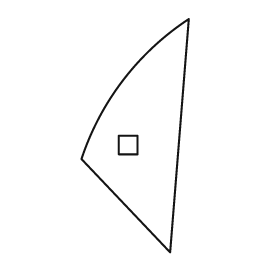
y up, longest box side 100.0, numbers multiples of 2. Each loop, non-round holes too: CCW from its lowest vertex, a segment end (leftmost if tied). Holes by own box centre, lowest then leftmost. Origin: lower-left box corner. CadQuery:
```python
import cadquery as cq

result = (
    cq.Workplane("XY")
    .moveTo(38.0, 0.0)
    .lineTo(46.0, 100.0)
    .threePointArc((18.0, 74.0), (0.0, 40.0))
    .close()
    .moveTo(16.0, 42.0)
    .lineTo(24.0, 42.0)
    .lineTo(24.0, 50.0)
    .lineTo(16.0, 50.0)
    .close()
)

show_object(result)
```